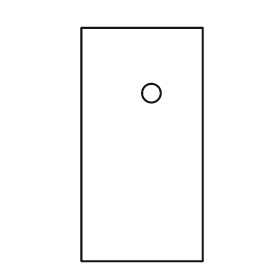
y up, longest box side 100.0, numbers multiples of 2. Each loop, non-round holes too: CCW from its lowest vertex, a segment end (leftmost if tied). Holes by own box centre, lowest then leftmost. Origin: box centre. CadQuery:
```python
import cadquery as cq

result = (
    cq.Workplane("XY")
    .moveTo(-26.0, -50.0)
    .lineTo(26.0, -50.0)
    .lineTo(26.0, 50.0)
    .lineTo(-26.0, 50.0)
    .close()
    .moveTo(4.0, 22.0)
    .circle(4.0)
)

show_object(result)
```